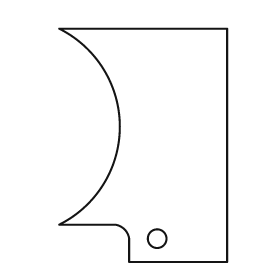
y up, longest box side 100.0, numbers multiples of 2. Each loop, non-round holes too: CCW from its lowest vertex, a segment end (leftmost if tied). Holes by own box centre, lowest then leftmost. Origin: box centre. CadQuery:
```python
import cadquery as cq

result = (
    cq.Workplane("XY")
    .moveTo(-6.0, -50.0)
    .lineTo(36.0, -50.0)
    .lineTo(36.0, 50.0)
    .lineTo(-36.0, 50.0)
    .threePointArc((-10.0, 8.0), (-36.0, -34.0))
    .lineTo(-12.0, -34.0)
    .threePointArc((-8.0, -36.0), (-6.0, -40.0))
    .close()
    .moveTo(6.0, -40.0)
    .circle(4.0)
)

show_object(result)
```